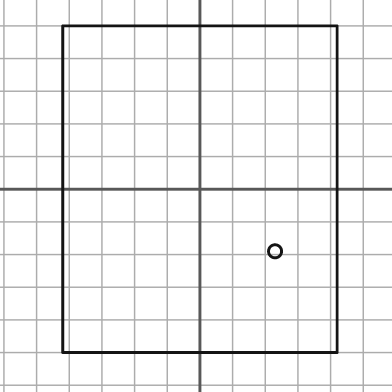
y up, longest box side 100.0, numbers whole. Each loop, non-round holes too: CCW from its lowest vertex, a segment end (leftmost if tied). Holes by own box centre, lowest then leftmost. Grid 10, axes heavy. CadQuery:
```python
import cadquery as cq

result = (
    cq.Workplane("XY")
    .moveTo(-42.0, -50.0)
    .lineTo(42.0, -50.0)
    .lineTo(42.0, 50.0)
    .lineTo(-42.0, 50.0)
    .close()
    .moveTo(23.0, -19.0)
    .circle(2.0)
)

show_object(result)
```